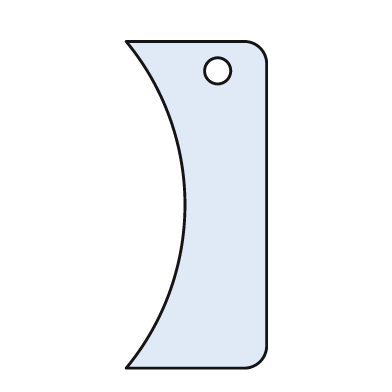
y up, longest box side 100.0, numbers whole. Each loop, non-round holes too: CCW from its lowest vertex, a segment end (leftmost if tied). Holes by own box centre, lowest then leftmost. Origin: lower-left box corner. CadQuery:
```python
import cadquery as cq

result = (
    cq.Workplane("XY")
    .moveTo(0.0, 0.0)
    .lineTo(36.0, 0.0)
    .threePointArc((41.0, 2.0), (43.0, 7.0))
    .lineTo(43.0, 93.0)
    .threePointArc((41.0, 98.0), (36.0, 100.0))
    .lineTo(0.0, 100.0)
    .threePointArc((18.0, 50.0), (0.0, 0.0))
    .close()
    .moveTo(28.0, 91.0)
    .circle(4.0)
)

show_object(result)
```